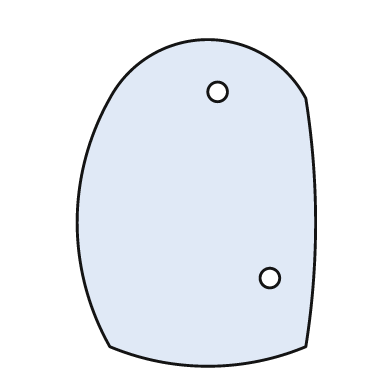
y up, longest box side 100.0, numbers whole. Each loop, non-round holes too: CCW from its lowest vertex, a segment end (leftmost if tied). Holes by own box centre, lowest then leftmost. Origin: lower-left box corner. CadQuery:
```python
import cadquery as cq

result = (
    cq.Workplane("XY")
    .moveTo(10.0, 6.0)
    .threePointArc((40.0, 0.0), (70.0, 6.0))
    .threePointArc((73.0, 44.0), (70.0, 82.0))
    .threePointArc((40.0, 100.0), (10.0, 82.0))
    .threePointArc((0.0, 44.0), (10.0, 6.0))
    .close()
    .moveTo(59.0, 27.0)
    .circle(3.0)
    .moveTo(43.0, 84.0)
    .circle(3.0)
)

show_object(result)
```